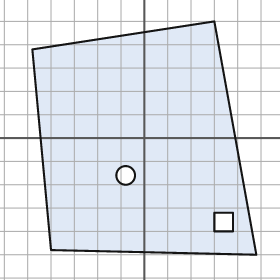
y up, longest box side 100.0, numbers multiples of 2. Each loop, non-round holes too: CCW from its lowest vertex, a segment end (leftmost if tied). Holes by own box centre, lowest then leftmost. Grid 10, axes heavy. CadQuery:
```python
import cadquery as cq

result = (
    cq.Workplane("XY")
    .moveTo(48.0, -50.0)
    .lineTo(30.0, 50.0)
    .lineTo(-48.0, 38.0)
    .lineTo(-40.0, -48.0)
    .close()
    .moveTo(30.0, -40.0)
    .lineTo(38.0, -40.0)
    .lineTo(38.0, -32.0)
    .lineTo(30.0, -32.0)
    .close()
    .moveTo(-8.0, -16.0)
    .circle(4.0)
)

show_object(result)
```